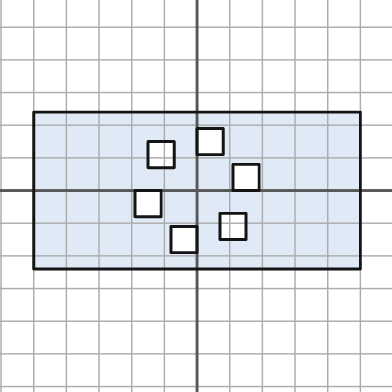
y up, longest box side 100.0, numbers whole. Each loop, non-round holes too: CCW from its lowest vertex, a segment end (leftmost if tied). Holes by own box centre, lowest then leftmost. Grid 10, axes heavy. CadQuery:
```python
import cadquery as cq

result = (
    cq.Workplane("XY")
    .moveTo(-50.0, -24.0)
    .lineTo(50.0, -24.0)
    .lineTo(50.0, 24.0)
    .lineTo(-50.0, 24.0)
    .close()
    .moveTo(-8.0, -19.0)
    .lineTo(0.0, -19.0)
    .lineTo(0.0, -11.0)
    .lineTo(-8.0, -11.0)
    .close()
    .moveTo(7.0, -15.0)
    .lineTo(15.0, -15.0)
    .lineTo(15.0, -7.0)
    .lineTo(7.0, -7.0)
    .close()
    .moveTo(-19.0, -8.0)
    .lineTo(-11.0, -8.0)
    .lineTo(-11.0, 0.0)
    .lineTo(-19.0, 0.0)
    .close()
    .moveTo(11.0, 0.0)
    .lineTo(19.0, 0.0)
    .lineTo(19.0, 8.0)
    .lineTo(11.0, 8.0)
    .close()
    .moveTo(-15.0, 7.0)
    .lineTo(-7.0, 7.0)
    .lineTo(-7.0, 15.0)
    .lineTo(-15.0, 15.0)
    .close()
    .moveTo(0.0, 11.0)
    .lineTo(8.0, 11.0)
    .lineTo(8.0, 19.0)
    .lineTo(0.0, 19.0)
    .close()
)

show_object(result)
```